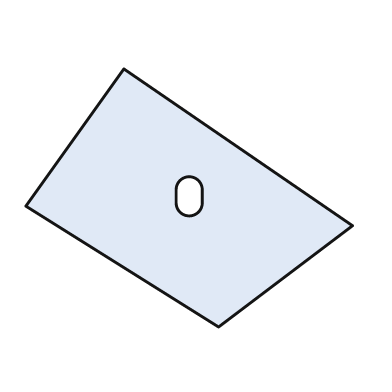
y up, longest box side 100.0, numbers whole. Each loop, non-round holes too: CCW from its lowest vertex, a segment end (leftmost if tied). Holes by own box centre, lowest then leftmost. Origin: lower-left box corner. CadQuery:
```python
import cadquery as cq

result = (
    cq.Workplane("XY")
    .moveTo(59.0, 0.0)
    .lineTo(100.0, 31.0)
    .lineTo(30.0, 79.0)
    .lineTo(0.0, 37.0)
    .close()
    .moveTo(46.0, 38.0)
    .threePointArc((50.0, 34.0), (54.0, 38.0))
    .lineTo(54.0, 42.0)
    .threePointArc((50.0, 46.0), (46.0, 42.0))
    .close()
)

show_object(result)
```